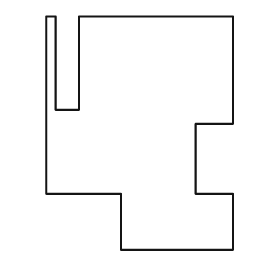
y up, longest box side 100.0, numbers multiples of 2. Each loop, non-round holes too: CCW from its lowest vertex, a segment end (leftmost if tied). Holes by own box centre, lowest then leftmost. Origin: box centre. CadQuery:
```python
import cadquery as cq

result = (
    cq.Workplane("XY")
    .moveTo(-8.0, -50.0)
    .lineTo(40.0, -50.0)
    .lineTo(40.0, -26.0)
    .lineTo(24.0, -26.0)
    .lineTo(24.0, 4.0)
    .lineTo(40.0, 4.0)
    .lineTo(40.0, 50.0)
    .lineTo(-26.0, 50.0)
    .lineTo(-26.0, 10.0)
    .lineTo(-36.0, 10.0)
    .lineTo(-36.0, 50.0)
    .lineTo(-40.0, 50.0)
    .lineTo(-40.0, -26.0)
    .lineTo(-8.0, -26.0)
    .close()
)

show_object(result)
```